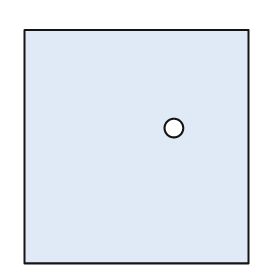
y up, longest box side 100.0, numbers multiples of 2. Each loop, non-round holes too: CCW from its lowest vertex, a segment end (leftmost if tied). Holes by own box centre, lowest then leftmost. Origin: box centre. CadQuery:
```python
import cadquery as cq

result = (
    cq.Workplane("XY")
    .moveTo(-48.0, -50.0)
    .lineTo(48.0, -50.0)
    .lineTo(48.0, 50.0)
    .lineTo(-48.0, 50.0)
    .close()
    .moveTo(16.0, 8.0)
    .circle(4.0)
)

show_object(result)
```